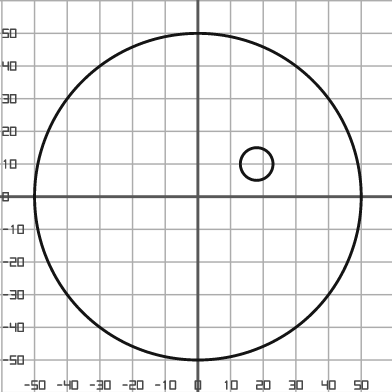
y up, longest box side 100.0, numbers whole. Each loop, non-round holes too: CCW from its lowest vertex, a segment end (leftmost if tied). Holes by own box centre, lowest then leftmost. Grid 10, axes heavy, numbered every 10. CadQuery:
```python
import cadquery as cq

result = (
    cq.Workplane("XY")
    .moveTo(0.0, 0.0)
    .circle(50.0)
    .moveTo(18.0, 10.0)
    .circle(5.0)
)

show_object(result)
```